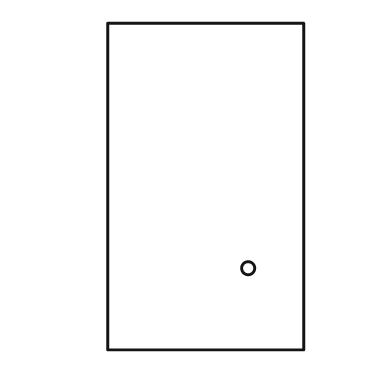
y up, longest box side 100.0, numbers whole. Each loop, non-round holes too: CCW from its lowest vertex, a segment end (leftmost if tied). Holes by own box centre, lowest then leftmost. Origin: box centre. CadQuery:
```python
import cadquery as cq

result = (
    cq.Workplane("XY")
    .moveTo(-30.0, -50.0)
    .lineTo(30.0, -50.0)
    .lineTo(30.0, 50.0)
    .lineTo(-30.0, 50.0)
    .close()
    .moveTo(13.0, -25.0)
    .circle(2.0)
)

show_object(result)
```